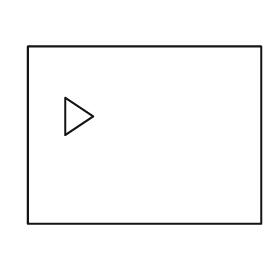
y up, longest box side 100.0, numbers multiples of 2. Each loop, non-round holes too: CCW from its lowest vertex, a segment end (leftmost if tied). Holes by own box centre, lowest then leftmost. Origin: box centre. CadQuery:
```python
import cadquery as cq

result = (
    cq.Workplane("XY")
    .moveTo(-50.0, -38.0)
    .lineTo(50.0, -38.0)
    .lineTo(50.0, 38.0)
    .lineTo(-50.0, 38.0)
    .close()
    .moveTo(-34.0, 0.0)
    .lineTo(-22.0, 8.0)
    .lineTo(-34.0, 16.0)
    .close()
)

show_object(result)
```